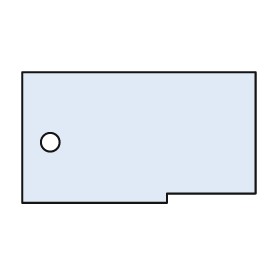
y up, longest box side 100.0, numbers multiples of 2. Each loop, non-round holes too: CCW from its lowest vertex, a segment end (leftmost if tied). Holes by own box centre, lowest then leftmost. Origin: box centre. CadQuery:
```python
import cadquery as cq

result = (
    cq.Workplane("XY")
    .moveTo(-50.0, -28.0)
    .lineTo(12.0, -28.0)
    .lineTo(12.0, -24.0)
    .lineTo(50.0, -24.0)
    .lineTo(50.0, 28.0)
    .lineTo(-50.0, 28.0)
    .close()
    .moveTo(-38.0, -2.0)
    .circle(4.0)
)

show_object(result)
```